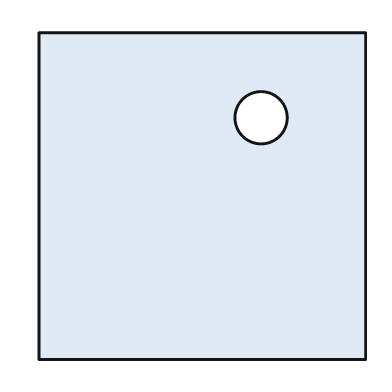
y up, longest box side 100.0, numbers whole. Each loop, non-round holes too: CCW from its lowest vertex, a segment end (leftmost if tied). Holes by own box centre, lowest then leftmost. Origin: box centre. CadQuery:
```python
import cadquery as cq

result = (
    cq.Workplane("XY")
    .moveTo(-50.0, -50.0)
    .lineTo(50.0, -50.0)
    .lineTo(50.0, 50.0)
    .lineTo(-50.0, 50.0)
    .close()
    .moveTo(18.0, 24.0)
    .circle(8.0)
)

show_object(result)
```